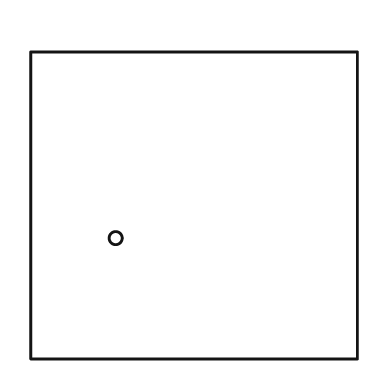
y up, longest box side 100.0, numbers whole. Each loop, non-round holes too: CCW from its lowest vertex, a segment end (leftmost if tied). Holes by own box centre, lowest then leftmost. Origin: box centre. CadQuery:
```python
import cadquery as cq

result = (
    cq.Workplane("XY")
    .moveTo(-50.0, -47.0)
    .lineTo(50.0, -47.0)
    .lineTo(50.0, 47.0)
    .lineTo(-50.0, 47.0)
    .close()
    .moveTo(-24.0, -10.0)
    .circle(2.0)
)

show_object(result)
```